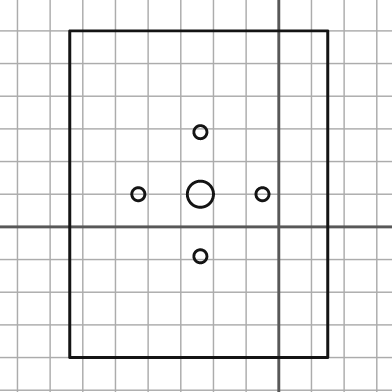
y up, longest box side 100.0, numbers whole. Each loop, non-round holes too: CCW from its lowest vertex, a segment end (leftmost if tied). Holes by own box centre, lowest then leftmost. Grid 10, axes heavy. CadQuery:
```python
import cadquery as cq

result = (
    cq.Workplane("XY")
    .moveTo(-64.0, -40.0)
    .lineTo(15.0, -40.0)
    .lineTo(15.0, 60.0)
    .lineTo(-64.0, 60.0)
    .close()
    .moveTo(-24.0, -9.0)
    .circle(2.0)
    .moveTo(-43.0, 10.0)
    .circle(2.0)
    .moveTo(-24.0, 10.0)
    .circle(4.0)
    .moveTo(-5.0, 10.0)
    .circle(2.0)
    .moveTo(-24.0, 29.0)
    .circle(2.0)
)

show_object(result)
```